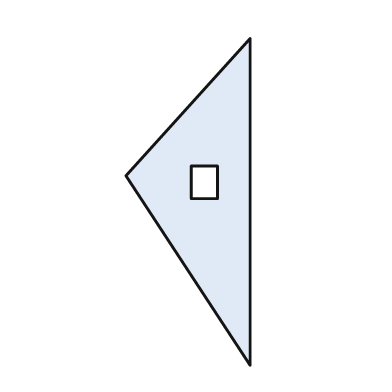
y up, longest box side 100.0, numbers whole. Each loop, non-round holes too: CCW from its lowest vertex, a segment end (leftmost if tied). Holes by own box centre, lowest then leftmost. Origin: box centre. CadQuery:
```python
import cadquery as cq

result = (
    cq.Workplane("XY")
    .moveTo(19.0, -50.0)
    .lineTo(19.0, 50.0)
    .lineTo(-19.0, 8.0)
    .close()
    .moveTo(1.0, 1.0)
    .lineTo(9.0, 1.0)
    .lineTo(9.0, 11.0)
    .lineTo(1.0, 11.0)
    .close()
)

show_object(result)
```